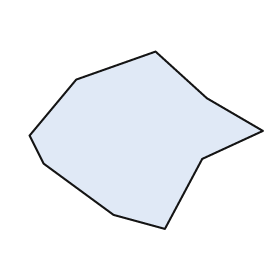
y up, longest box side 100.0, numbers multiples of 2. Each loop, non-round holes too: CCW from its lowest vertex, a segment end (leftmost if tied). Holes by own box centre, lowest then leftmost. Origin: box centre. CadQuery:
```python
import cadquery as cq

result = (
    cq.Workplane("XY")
    .moveTo(8.0, -38.0)
    .lineTo(24.0, -8.0)
    .lineTo(50.0, 4.0)
    .lineTo(26.0, 18.0)
    .lineTo(4.0, 38.0)
    .lineTo(-30.0, 26.0)
    .lineTo(-50.0, 2.0)
    .lineTo(-44.0, -10.0)
    .lineTo(-14.0, -32.0)
    .close()
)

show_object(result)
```